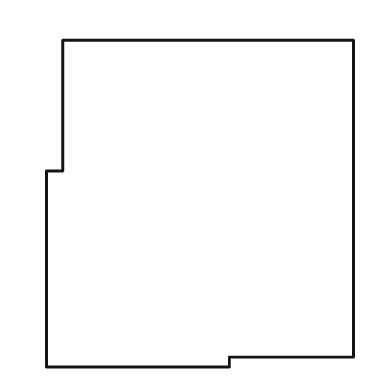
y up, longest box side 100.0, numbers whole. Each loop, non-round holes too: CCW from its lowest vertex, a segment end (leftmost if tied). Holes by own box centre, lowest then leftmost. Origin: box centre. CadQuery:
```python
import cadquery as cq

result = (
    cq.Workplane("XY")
    .moveTo(-47.0, -50.0)
    .lineTo(9.0, -50.0)
    .lineTo(9.0, -47.0)
    .lineTo(47.0, -47.0)
    .lineTo(47.0, 50.0)
    .lineTo(-42.0, 50.0)
    .lineTo(-42.0, 10.0)
    .lineTo(-47.0, 10.0)
    .close()
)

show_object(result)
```